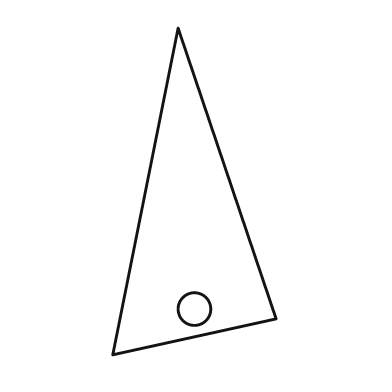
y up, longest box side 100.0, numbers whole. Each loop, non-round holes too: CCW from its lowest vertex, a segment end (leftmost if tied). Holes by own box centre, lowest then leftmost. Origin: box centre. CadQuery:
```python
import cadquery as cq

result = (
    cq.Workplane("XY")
    .moveTo(-25.0, -50.0)
    .lineTo(25.0, -39.0)
    .lineTo(-5.0, 50.0)
    .close()
    .moveTo(0.0, -36.0)
    .circle(5.0)
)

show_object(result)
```